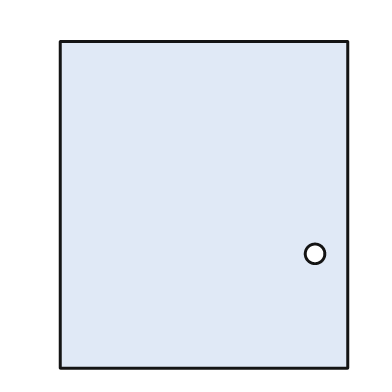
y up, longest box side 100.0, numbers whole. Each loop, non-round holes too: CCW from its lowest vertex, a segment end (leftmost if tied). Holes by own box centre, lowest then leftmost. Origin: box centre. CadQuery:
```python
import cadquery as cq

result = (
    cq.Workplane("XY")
    .moveTo(-44.0, -50.0)
    .lineTo(44.0, -50.0)
    .lineTo(44.0, 50.0)
    .lineTo(-44.0, 50.0)
    .close()
    .moveTo(34.0, -15.0)
    .circle(3.0)
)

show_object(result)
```